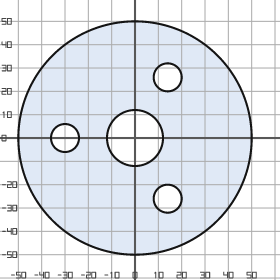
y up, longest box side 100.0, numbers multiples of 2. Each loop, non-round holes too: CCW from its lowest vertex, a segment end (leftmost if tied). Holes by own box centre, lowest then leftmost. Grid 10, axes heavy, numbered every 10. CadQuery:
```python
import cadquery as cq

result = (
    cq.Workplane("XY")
    .moveTo(0.0, 0.0)
    .circle(50.0)
    .moveTo(14.0, -26.0)
    .circle(6.0)
    .moveTo(-30.0, 0.0)
    .circle(6.0)
    .moveTo(0.0, 0.0)
    .circle(12.0)
    .moveTo(14.0, 26.0)
    .circle(6.0)
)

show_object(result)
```